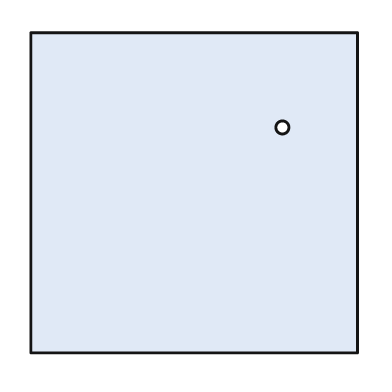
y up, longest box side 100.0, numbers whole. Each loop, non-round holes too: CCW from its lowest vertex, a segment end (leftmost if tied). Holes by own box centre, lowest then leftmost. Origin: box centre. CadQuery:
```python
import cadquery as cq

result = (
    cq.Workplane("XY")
    .moveTo(-50.0, -49.0)
    .lineTo(50.0, -49.0)
    .lineTo(50.0, 49.0)
    .lineTo(-50.0, 49.0)
    .close()
    .moveTo(27.0, 20.0)
    .circle(2.0)
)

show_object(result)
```